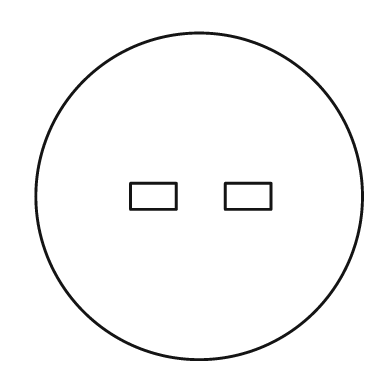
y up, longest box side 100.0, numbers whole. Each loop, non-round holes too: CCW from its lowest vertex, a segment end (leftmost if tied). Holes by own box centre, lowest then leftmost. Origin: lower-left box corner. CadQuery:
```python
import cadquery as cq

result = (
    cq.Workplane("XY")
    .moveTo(50.0, 50.0)
    .circle(50.0)
    .moveTo(29.0, 46.0)
    .lineTo(43.0, 46.0)
    .lineTo(43.0, 54.0)
    .lineTo(29.0, 54.0)
    .close()
    .moveTo(58.0, 46.0)
    .lineTo(72.0, 46.0)
    .lineTo(72.0, 54.0)
    .lineTo(58.0, 54.0)
    .close()
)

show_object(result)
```